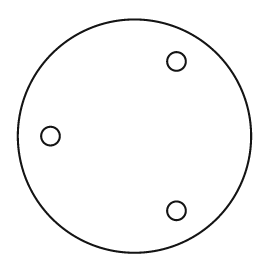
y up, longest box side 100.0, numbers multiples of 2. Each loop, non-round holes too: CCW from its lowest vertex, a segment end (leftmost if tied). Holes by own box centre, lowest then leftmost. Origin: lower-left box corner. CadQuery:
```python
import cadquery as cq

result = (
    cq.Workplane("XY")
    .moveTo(50.0, 50.0)
    .circle(50.0)
    .moveTo(68.0, 18.0)
    .circle(4.0)
    .moveTo(14.0, 50.0)
    .circle(4.0)
    .moveTo(68.0, 82.0)
    .circle(4.0)
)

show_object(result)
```